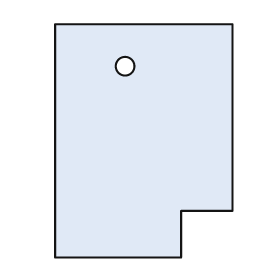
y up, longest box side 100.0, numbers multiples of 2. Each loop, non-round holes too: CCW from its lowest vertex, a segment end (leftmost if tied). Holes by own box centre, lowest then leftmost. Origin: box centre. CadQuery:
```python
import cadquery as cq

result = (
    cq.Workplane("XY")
    .moveTo(-38.0, -50.0)
    .lineTo(16.0, -50.0)
    .lineTo(16.0, -30.0)
    .lineTo(38.0, -30.0)
    .lineTo(38.0, 50.0)
    .lineTo(-38.0, 50.0)
    .close()
    .moveTo(-8.0, 32.0)
    .circle(4.0)
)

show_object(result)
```